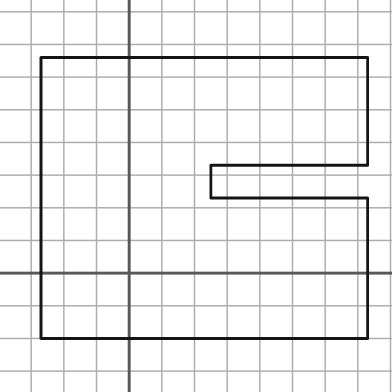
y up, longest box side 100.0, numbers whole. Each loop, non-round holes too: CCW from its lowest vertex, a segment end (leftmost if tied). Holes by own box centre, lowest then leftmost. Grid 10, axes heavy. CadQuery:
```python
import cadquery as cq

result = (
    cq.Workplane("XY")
    .moveTo(-27.0, -20.0)
    .lineTo(73.0, -20.0)
    .lineTo(73.0, 23.0)
    .lineTo(25.0, 23.0)
    .lineTo(25.0, 33.0)
    .lineTo(73.0, 33.0)
    .lineTo(73.0, 66.0)
    .lineTo(-27.0, 66.0)
    .close()
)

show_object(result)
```